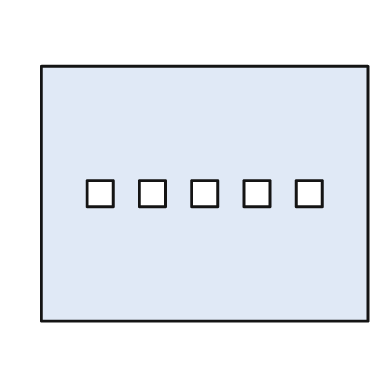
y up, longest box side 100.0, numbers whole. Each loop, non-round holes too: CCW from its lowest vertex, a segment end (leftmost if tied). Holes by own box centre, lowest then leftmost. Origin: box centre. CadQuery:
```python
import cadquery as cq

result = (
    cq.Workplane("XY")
    .moveTo(-50.0, -39.0)
    .lineTo(50.0, -39.0)
    .lineTo(50.0, 39.0)
    .lineTo(-50.0, 39.0)
    .close()
    .moveTo(-36.0, -4.0)
    .lineTo(-28.0, -4.0)
    .lineTo(-28.0, 4.0)
    .lineTo(-36.0, 4.0)
    .close()
    .moveTo(-20.0, -4.0)
    .lineTo(-12.0, -4.0)
    .lineTo(-12.0, 4.0)
    .lineTo(-20.0, 4.0)
    .close()
    .moveTo(-4.0, -4.0)
    .lineTo(4.0, -4.0)
    .lineTo(4.0, 4.0)
    .lineTo(-4.0, 4.0)
    .close()
    .moveTo(12.0, -4.0)
    .lineTo(20.0, -4.0)
    .lineTo(20.0, 4.0)
    .lineTo(12.0, 4.0)
    .close()
    .moveTo(28.0, -4.0)
    .lineTo(36.0, -4.0)
    .lineTo(36.0, 4.0)
    .lineTo(28.0, 4.0)
    .close()
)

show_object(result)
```